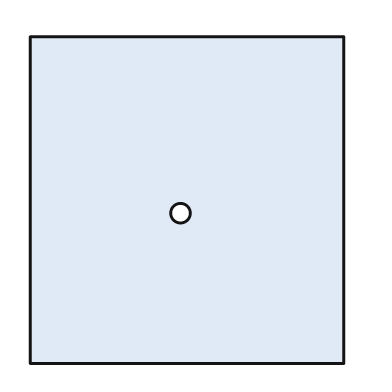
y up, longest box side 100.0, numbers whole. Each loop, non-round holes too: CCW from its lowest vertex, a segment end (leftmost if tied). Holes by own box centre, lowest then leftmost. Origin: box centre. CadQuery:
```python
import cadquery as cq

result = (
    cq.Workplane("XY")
    .moveTo(-48.0, -50.0)
    .lineTo(48.0, -50.0)
    .lineTo(48.0, 50.0)
    .lineTo(-48.0, 50.0)
    .close()
    .moveTo(-2.0, -4.0)
    .circle(3.0)
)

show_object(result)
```